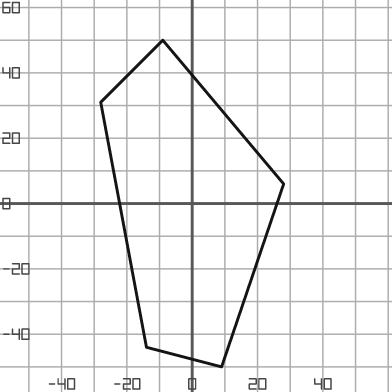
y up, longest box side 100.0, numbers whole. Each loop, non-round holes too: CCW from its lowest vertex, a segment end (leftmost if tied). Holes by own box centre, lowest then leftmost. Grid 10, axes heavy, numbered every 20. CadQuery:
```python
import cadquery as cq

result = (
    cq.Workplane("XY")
    .moveTo(9.0, -50.0)
    .lineTo(28.0, 6.0)
    .lineTo(-9.0, 50.0)
    .lineTo(-28.0, 31.0)
    .lineTo(-14.0, -44.0)
    .close()
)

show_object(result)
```